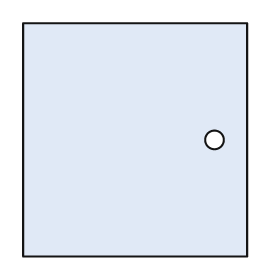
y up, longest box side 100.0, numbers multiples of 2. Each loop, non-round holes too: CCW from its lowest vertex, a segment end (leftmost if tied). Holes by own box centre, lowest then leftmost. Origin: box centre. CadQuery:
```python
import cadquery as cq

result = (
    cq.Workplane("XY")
    .moveTo(-48.0, -50.0)
    .lineTo(48.0, -50.0)
    .lineTo(48.0, 50.0)
    .lineTo(-48.0, 50.0)
    .close()
    .moveTo(34.0, 0.0)
    .circle(4.0)
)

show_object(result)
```